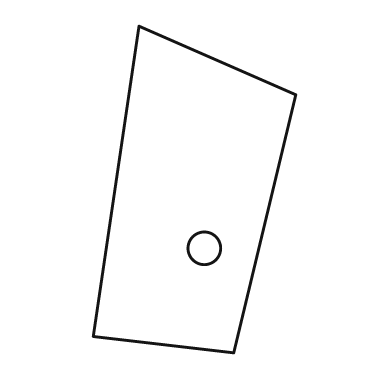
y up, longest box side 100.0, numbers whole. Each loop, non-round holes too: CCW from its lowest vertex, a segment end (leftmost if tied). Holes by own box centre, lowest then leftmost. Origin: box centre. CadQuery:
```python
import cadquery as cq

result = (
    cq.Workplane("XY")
    .moveTo(12.0, -50.0)
    .lineTo(31.0, 29.0)
    .lineTo(-17.0, 50.0)
    .lineTo(-31.0, -45.0)
    .close()
    .moveTo(3.0, -18.0)
    .circle(5.0)
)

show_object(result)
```